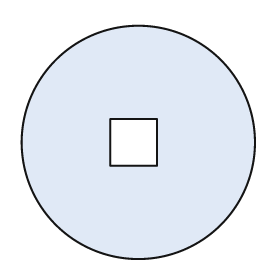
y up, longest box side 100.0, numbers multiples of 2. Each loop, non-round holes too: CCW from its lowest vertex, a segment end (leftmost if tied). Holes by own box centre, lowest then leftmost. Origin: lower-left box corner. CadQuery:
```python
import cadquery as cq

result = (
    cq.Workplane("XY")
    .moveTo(50.0, 50.0)
    .circle(50.0)
    .moveTo(38.0, 40.0)
    .lineTo(58.0, 40.0)
    .lineTo(58.0, 60.0)
    .lineTo(38.0, 60.0)
    .close()
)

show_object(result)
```